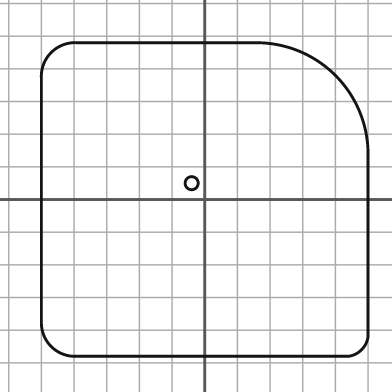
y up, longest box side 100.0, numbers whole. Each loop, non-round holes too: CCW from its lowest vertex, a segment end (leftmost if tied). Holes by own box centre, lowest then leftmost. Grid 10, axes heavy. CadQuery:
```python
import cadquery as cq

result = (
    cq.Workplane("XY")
    .moveTo(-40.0, -48.0)
    .lineTo(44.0, -48.0)
    .threePointArc((48.0, -46.0), (50.0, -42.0))
    .lineTo(50.0, 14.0)
    .threePointArc((40.0, 38.0), (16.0, 48.0))
    .lineTo(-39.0, 48.0)
    .threePointArc((-47.0, 45.0), (-50.0, 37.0))
    .lineTo(-50.0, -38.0)
    .threePointArc((-47.0, -45.0), (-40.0, -48.0))
    .close()
    .moveTo(-4.0, 5.0)
    .circle(2.0)
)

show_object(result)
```